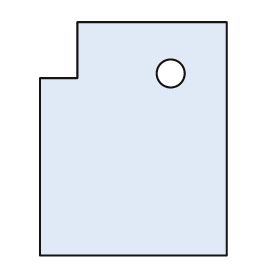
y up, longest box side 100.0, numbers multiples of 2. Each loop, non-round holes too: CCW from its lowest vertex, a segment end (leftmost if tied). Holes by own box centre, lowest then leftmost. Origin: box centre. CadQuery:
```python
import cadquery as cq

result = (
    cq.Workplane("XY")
    .moveTo(-40.0, -50.0)
    .lineTo(40.0, -50.0)
    .lineTo(40.0, 50.0)
    .lineTo(-24.0, 50.0)
    .lineTo(-24.0, 26.0)
    .lineTo(-40.0, 26.0)
    .close()
    .moveTo(16.0, 28.0)
    .circle(6.0)
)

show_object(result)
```